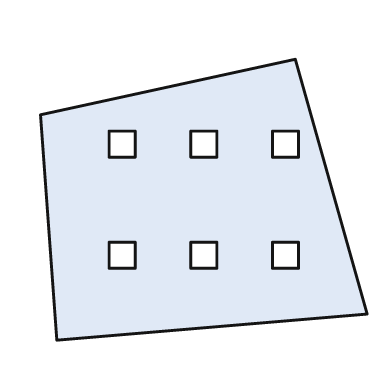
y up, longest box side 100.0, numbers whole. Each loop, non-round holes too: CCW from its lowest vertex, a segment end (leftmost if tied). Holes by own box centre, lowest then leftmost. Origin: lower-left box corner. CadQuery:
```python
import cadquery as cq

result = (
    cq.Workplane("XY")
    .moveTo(5.0, 0.0)
    .lineTo(100.0, 8.0)
    .lineTo(78.0, 86.0)
    .lineTo(0.0, 69.0)
    .close()
    .moveTo(21.0, 22.0)
    .lineTo(29.0, 22.0)
    .lineTo(29.0, 30.0)
    .lineTo(21.0, 30.0)
    .close()
    .moveTo(46.0, 22.0)
    .lineTo(54.0, 22.0)
    .lineTo(54.0, 30.0)
    .lineTo(46.0, 30.0)
    .close()
    .moveTo(71.0, 22.0)
    .lineTo(79.0, 22.0)
    .lineTo(79.0, 30.0)
    .lineTo(71.0, 30.0)
    .close()
    .moveTo(21.0, 56.0)
    .lineTo(29.0, 56.0)
    .lineTo(29.0, 64.0)
    .lineTo(21.0, 64.0)
    .close()
    .moveTo(46.0, 56.0)
    .lineTo(54.0, 56.0)
    .lineTo(54.0, 64.0)
    .lineTo(46.0, 64.0)
    .close()
    .moveTo(71.0, 56.0)
    .lineTo(79.0, 56.0)
    .lineTo(79.0, 64.0)
    .lineTo(71.0, 64.0)
    .close()
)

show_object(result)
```